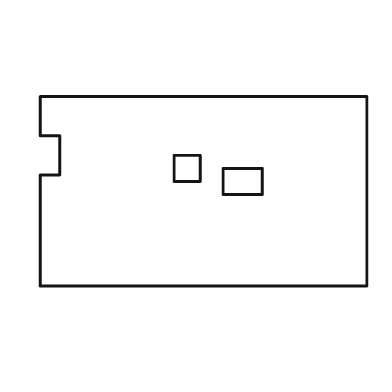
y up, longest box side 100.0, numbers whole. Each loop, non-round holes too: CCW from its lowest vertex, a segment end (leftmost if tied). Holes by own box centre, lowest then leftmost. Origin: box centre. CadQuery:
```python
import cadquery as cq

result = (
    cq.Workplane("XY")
    .moveTo(-50.0, -29.0)
    .lineTo(50.0, -29.0)
    .lineTo(50.0, 29.0)
    .lineTo(-50.0, 29.0)
    .lineTo(-50.0, 17.0)
    .lineTo(-44.0, 17.0)
    .lineTo(-44.0, 5.0)
    .lineTo(-50.0, 5.0)
    .close()
    .moveTo(6.0, -1.0)
    .lineTo(18.0, -1.0)
    .lineTo(18.0, 7.0)
    .lineTo(6.0, 7.0)
    .close()
    .moveTo(-9.0, 3.0)
    .lineTo(-1.0, 3.0)
    .lineTo(-1.0, 11.0)
    .lineTo(-9.0, 11.0)
    .close()
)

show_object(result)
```